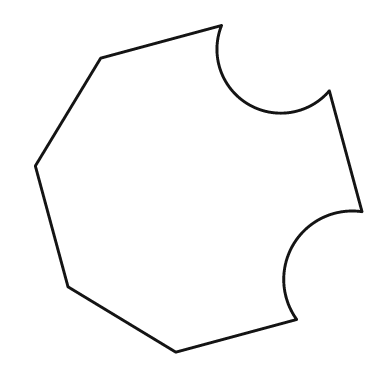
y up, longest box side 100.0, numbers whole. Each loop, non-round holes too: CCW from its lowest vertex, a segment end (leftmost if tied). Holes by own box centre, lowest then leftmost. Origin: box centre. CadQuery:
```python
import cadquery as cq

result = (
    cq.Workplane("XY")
    .moveTo(-7.0, -50.0)
    .lineTo(30.0, -40.0)
    .threePointArc((29.0, -17.0), (50.0, -7.0))
    .lineTo(40.0, 30.0)
    .threePointArc((15.0, 26.0), (7.0, 50.0))
    .lineTo(-30.0, 40.0)
    .lineTo(-50.0, 7.0)
    .lineTo(-40.0, -30.0)
    .close()
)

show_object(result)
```